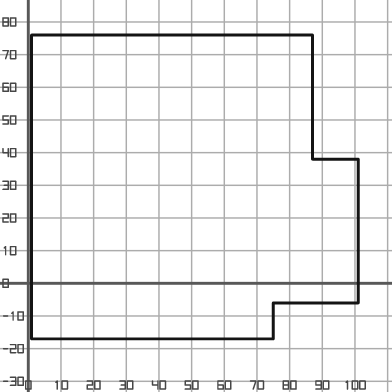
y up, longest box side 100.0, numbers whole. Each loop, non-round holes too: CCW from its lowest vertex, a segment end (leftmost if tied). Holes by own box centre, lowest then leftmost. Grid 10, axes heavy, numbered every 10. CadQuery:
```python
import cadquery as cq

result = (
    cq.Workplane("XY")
    .moveTo(1.0, -17.0)
    .lineTo(75.0, -17.0)
    .lineTo(75.0, -6.0)
    .lineTo(101.0, -6.0)
    .lineTo(101.0, 38.0)
    .lineTo(87.0, 38.0)
    .lineTo(87.0, 76.0)
    .lineTo(1.0, 76.0)
    .close()
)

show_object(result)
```